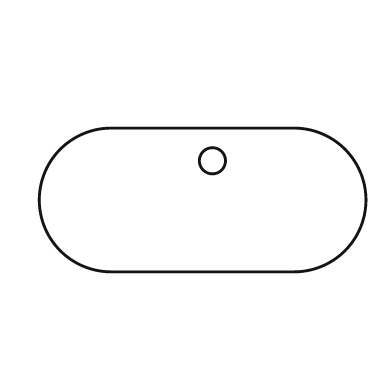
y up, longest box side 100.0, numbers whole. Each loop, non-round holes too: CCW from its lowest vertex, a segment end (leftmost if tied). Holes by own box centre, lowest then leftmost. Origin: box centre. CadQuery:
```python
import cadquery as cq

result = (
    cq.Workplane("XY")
    .moveTo(-28.0, -22.0)
    .lineTo(28.0, -22.0)
    .threePointArc((50.0, 0.0), (28.0, 22.0))
    .lineTo(-28.0, 22.0)
    .threePointArc((-50.0, 0.0), (-28.0, -22.0))
    .close()
    .moveTo(3.0, 12.0)
    .circle(4.0)
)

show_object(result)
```